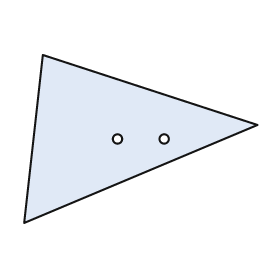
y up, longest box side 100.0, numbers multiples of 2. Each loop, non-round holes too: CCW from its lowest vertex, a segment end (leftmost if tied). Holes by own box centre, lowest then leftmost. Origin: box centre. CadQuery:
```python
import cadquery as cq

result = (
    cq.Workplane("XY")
    .moveTo(-50.0, -36.0)
    .lineTo(50.0, 6.0)
    .lineTo(-42.0, 36.0)
    .close()
    .moveTo(-10.0, 0.0)
    .circle(2.0)
    .moveTo(10.0, 0.0)
    .circle(2.0)
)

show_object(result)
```